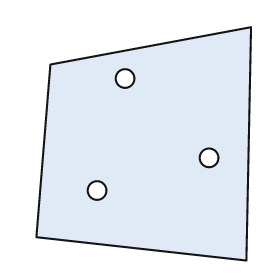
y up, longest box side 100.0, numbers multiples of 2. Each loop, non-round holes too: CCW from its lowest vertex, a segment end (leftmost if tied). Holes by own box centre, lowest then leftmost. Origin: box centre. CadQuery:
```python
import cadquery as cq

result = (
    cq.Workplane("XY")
    .moveTo(44.0, -50.0)
    .lineTo(46.0, 50.0)
    .lineTo(-40.0, 34.0)
    .lineTo(-46.0, -40.0)
    .close()
    .moveTo(-20.0, -20.0)
    .circle(4.0)
    .moveTo(28.0, -6.0)
    .circle(4.0)
    .moveTo(-8.0, 28.0)
    .circle(4.0)
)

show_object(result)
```